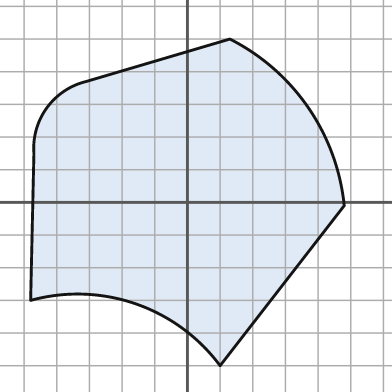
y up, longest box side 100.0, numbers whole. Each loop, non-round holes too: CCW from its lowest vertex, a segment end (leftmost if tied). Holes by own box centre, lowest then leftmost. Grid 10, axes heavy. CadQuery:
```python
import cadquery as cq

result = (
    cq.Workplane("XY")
    .moveTo(10.0, -50.0)
    .lineTo(48.0, -1.0)
    .threePointArc((37.0, 29.0), (13.0, 50.0))
    .lineTo(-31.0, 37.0)
    .threePointArc((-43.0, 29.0), (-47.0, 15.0))
    .lineTo(-48.0, -30.0)
    .threePointArc((-16.0, -31.0), (10.0, -50.0))
    .close()
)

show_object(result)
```